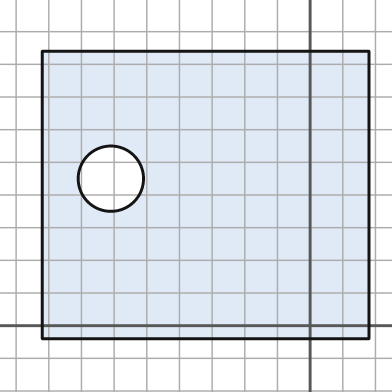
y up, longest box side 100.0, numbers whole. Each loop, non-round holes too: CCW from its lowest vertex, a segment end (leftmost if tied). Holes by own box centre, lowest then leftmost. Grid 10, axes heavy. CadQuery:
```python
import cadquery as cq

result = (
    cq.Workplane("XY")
    .moveTo(-82.0, -4.0)
    .lineTo(18.0, -4.0)
    .lineTo(18.0, 84.0)
    .lineTo(-82.0, 84.0)
    .close()
    .moveTo(-61.0, 45.0)
    .circle(10.0)
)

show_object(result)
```